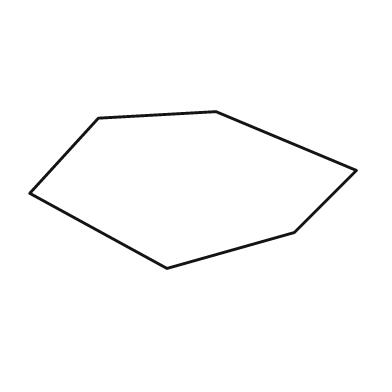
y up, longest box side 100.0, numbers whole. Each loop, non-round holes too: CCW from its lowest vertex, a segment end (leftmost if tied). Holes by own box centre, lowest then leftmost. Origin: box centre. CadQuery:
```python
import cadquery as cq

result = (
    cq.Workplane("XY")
    .moveTo(-8.0, -24.0)
    .lineTo(31.0, -13.0)
    .lineTo(50.0, 6.0)
    .lineTo(7.0, 24.0)
    .lineTo(-29.0, 22.0)
    .lineTo(-50.0, -1.0)
    .close()
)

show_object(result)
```